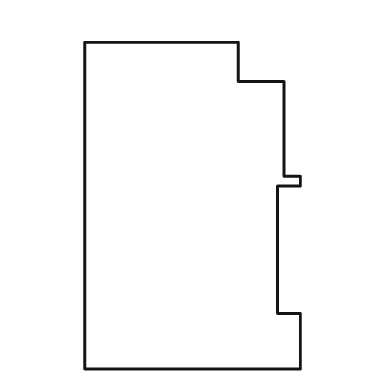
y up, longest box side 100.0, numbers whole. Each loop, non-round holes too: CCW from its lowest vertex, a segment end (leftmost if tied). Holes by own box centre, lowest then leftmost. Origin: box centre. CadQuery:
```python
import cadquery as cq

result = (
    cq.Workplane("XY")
    .moveTo(-33.0, -50.0)
    .lineTo(33.0, -50.0)
    .lineTo(33.0, -33.0)
    .lineTo(26.0, -33.0)
    .lineTo(26.0, 6.0)
    .lineTo(33.0, 6.0)
    .lineTo(33.0, 9.0)
    .lineTo(28.0, 9.0)
    .lineTo(28.0, 38.0)
    .lineTo(14.0, 38.0)
    .lineTo(14.0, 50.0)
    .lineTo(-33.0, 50.0)
    .close()
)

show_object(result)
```